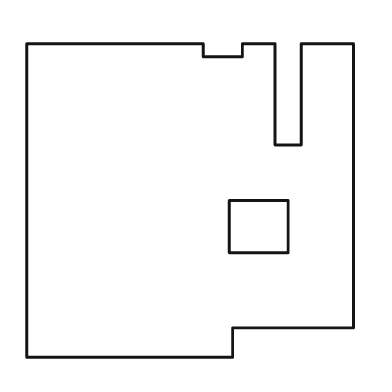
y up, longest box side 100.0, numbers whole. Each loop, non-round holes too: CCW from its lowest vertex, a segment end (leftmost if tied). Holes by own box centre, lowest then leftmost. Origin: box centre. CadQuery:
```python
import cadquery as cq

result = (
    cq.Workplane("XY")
    .moveTo(-50.0, -48.0)
    .lineTo(13.0, -48.0)
    .lineTo(13.0, -39.0)
    .lineTo(50.0, -39.0)
    .lineTo(50.0, 48.0)
    .lineTo(34.0, 48.0)
    .lineTo(34.0, 17.0)
    .lineTo(26.0, 17.0)
    .lineTo(26.0, 48.0)
    .lineTo(16.0, 48.0)
    .lineTo(16.0, 44.0)
    .lineTo(4.0, 44.0)
    .lineTo(4.0, 48.0)
    .lineTo(-50.0, 48.0)
    .close()
    .moveTo(12.0, -16.0)
    .lineTo(30.0, -16.0)
    .lineTo(30.0, 0.0)
    .lineTo(12.0, 0.0)
    .close()
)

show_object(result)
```